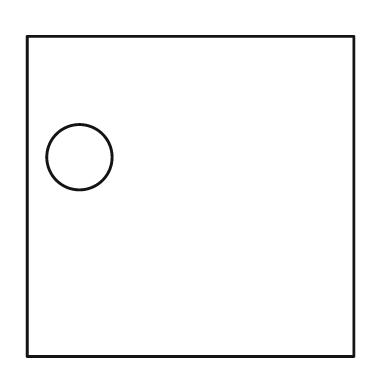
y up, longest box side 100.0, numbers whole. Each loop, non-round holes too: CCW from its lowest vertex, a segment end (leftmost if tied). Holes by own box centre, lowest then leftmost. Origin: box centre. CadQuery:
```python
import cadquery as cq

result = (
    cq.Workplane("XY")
    .moveTo(-50.0, -49.0)
    .lineTo(50.0, -49.0)
    .lineTo(50.0, 49.0)
    .lineTo(-50.0, 49.0)
    .close()
    .moveTo(-34.0, 12.0)
    .circle(10.0)
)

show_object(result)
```